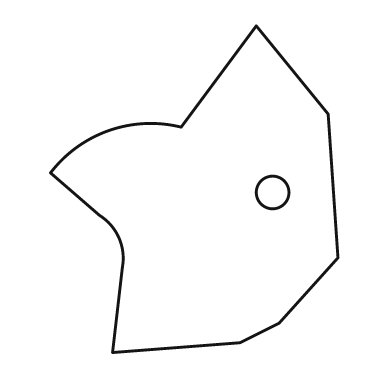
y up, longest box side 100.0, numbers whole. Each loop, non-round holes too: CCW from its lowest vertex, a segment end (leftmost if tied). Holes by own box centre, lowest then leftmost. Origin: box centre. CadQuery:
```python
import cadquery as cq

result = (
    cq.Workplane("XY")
    .moveTo(-25.0, -50.0)
    .lineTo(14.0, -47.0)
    .lineTo(26.0, -41.0)
    .lineTo(44.0, -21.0)
    .lineTo(41.0, 23.0)
    .lineTo(19.0, 50.0)
    .lineTo(-4.0, 19.0)
    .threePointArc((-26.0, 18.0), (-44.0, 5.0))
    .lineTo(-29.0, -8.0)
    .threePointArc((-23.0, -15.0), (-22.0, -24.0))
    .close()
    .moveTo(24.0, -1.0)
    .circle(5.0)
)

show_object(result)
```